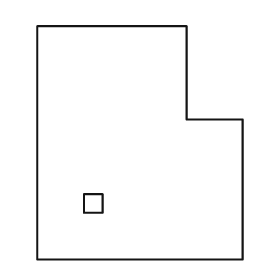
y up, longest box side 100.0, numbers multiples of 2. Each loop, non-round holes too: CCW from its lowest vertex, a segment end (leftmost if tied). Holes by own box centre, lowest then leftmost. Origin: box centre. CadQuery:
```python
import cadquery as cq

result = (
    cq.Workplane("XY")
    .moveTo(-44.0, -50.0)
    .lineTo(44.0, -50.0)
    .lineTo(44.0, 10.0)
    .lineTo(20.0, 10.0)
    .lineTo(20.0, 50.0)
    .lineTo(-44.0, 50.0)
    .close()
    .moveTo(-24.0, -30.0)
    .lineTo(-16.0, -30.0)
    .lineTo(-16.0, -22.0)
    .lineTo(-24.0, -22.0)
    .close()
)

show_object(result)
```